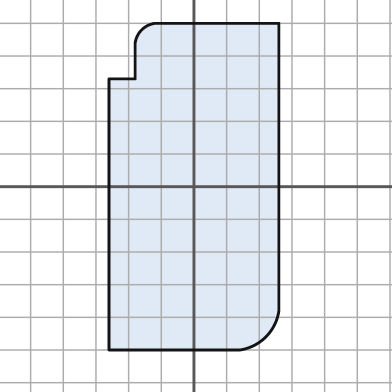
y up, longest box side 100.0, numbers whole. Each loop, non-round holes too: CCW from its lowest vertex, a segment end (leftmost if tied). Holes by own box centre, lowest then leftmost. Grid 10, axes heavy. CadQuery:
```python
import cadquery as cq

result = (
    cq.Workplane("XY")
    .moveTo(-26.0, -50.0)
    .lineTo(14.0, -50.0)
    .threePointArc((22.0, -46.0), (26.0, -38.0))
    .lineTo(26.0, 50.0)
    .lineTo(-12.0, 50.0)
    .threePointArc((-16.0, 48.0), (-18.0, 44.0))
    .lineTo(-18.0, 33.0)
    .lineTo(-26.0, 33.0)
    .close()
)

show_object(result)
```